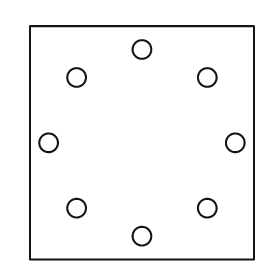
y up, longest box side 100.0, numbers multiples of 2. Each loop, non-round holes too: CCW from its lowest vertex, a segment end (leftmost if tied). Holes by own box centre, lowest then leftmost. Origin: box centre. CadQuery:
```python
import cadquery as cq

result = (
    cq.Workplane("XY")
    .moveTo(-48.0, -50.0)
    .lineTo(48.0, -50.0)
    .lineTo(48.0, 50.0)
    .lineTo(-48.0, 50.0)
    .close()
    .moveTo(0.0, -40.0)
    .circle(4.0)
    .moveTo(-28.0, -28.0)
    .circle(4.0)
    .moveTo(28.0, -28.0)
    .circle(4.0)
    .moveTo(-40.0, 0.0)
    .circle(4.0)
    .moveTo(40.0, 0.0)
    .circle(4.0)
    .moveTo(-28.0, 28.0)
    .circle(4.0)
    .moveTo(28.0, 28.0)
    .circle(4.0)
    .moveTo(0.0, 40.0)
    .circle(4.0)
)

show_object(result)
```